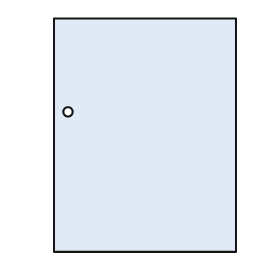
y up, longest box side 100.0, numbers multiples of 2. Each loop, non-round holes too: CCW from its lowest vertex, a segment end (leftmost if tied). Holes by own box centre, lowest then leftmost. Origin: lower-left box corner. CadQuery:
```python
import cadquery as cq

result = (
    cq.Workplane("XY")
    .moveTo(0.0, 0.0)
    .lineTo(78.0, 0.0)
    .lineTo(78.0, 100.0)
    .lineTo(0.0, 100.0)
    .close()
    .moveTo(6.0, 60.0)
    .circle(2.0)
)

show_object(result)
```